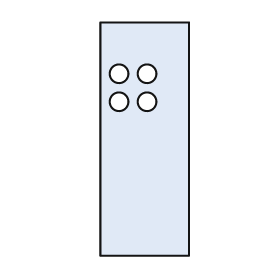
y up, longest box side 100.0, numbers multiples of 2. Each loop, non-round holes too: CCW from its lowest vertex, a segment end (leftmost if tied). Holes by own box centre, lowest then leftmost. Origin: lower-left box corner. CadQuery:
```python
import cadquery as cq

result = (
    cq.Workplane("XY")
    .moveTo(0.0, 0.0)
    .lineTo(38.0, 0.0)
    .lineTo(38.0, 100.0)
    .lineTo(0.0, 100.0)
    .close()
    .moveTo(8.0, 66.0)
    .circle(4.0)
    .moveTo(20.0, 66.0)
    .circle(4.0)
    .moveTo(8.0, 78.0)
    .circle(4.0)
    .moveTo(20.0, 78.0)
    .circle(4.0)
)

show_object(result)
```